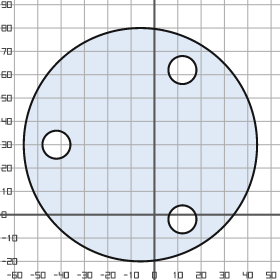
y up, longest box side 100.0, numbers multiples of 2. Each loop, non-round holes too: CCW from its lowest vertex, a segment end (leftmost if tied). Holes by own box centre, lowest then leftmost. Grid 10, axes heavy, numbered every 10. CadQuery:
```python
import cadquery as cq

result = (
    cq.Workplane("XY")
    .moveTo(-6.0, 30.0)
    .circle(50.0)
    .moveTo(12.0, -2.0)
    .circle(6.0)
    .moveTo(-42.0, 30.0)
    .circle(6.0)
    .moveTo(12.0, 62.0)
    .circle(6.0)
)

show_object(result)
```